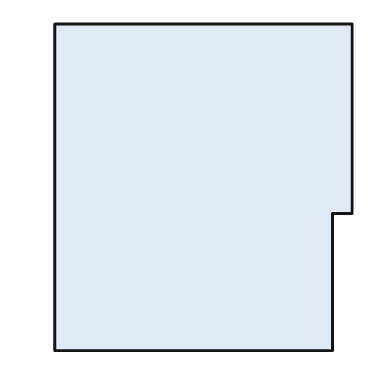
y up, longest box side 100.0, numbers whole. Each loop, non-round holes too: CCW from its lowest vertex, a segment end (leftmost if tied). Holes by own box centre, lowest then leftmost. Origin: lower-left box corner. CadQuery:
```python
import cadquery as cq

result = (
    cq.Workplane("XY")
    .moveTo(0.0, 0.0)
    .lineTo(85.0, 0.0)
    .lineTo(85.0, 42.0)
    .lineTo(91.0, 42.0)
    .lineTo(91.0, 100.0)
    .lineTo(0.0, 100.0)
    .close()
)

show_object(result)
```